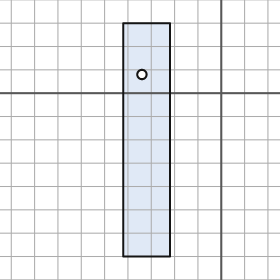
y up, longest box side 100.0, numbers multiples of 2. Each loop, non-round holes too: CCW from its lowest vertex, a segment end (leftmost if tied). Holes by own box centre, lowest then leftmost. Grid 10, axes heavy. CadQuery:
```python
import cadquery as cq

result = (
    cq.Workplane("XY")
    .moveTo(-42.0, -70.0)
    .lineTo(-22.0, -70.0)
    .lineTo(-22.0, 30.0)
    .lineTo(-42.0, 30.0)
    .close()
    .moveTo(-34.0, 8.0)
    .circle(2.0)
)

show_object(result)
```